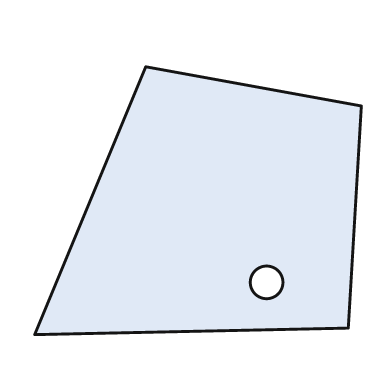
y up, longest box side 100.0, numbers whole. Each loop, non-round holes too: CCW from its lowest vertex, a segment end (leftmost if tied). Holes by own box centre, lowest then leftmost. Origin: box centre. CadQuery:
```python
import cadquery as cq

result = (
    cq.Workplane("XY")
    .moveTo(-50.0, -41.0)
    .lineTo(46.0, -39.0)
    .lineTo(50.0, 29.0)
    .lineTo(-16.0, 41.0)
    .close()
    .moveTo(21.0, -25.0)
    .circle(5.0)
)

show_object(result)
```